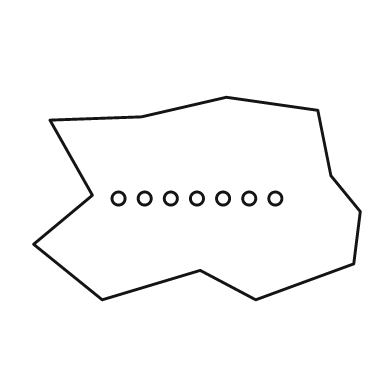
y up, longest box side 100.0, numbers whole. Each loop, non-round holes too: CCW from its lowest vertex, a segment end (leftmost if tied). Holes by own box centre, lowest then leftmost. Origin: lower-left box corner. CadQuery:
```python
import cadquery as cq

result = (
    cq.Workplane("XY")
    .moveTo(21.0, 0.0)
    .lineTo(51.0, 9.0)
    .lineTo(68.0, 0.0)
    .lineTo(98.0, 11.0)
    .lineTo(100.0, 27.0)
    .lineTo(91.0, 38.0)
    .lineTo(87.0, 58.0)
    .lineTo(59.0, 62.0)
    .lineTo(33.0, 56.0)
    .lineTo(5.0, 55.0)
    .lineTo(18.0, 32.0)
    .lineTo(0.0, 17.0)
    .close()
    .moveTo(26.0, 31.0)
    .circle(2.0)
    .moveTo(34.0, 31.0)
    .circle(2.0)
    .moveTo(42.0, 31.0)
    .circle(2.0)
    .moveTo(50.0, 31.0)
    .circle(2.0)
    .moveTo(58.0, 31.0)
    .circle(2.0)
    .moveTo(66.0, 31.0)
    .circle(2.0)
    .moveTo(74.0, 31.0)
    .circle(2.0)
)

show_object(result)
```